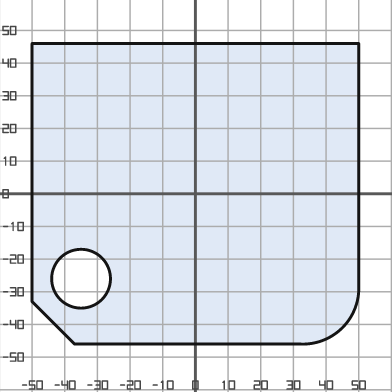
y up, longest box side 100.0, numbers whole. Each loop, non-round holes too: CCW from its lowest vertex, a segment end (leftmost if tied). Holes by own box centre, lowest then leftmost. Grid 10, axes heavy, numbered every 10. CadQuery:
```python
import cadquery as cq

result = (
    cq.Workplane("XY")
    .moveTo(-37.0, -46.0)
    .lineTo(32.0, -46.0)
    .threePointArc((45.0, -41.0), (50.0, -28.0))
    .lineTo(50.0, 46.0)
    .lineTo(-50.0, 46.0)
    .lineTo(-50.0, -33.0)
    .close()
    .moveTo(-35.0, -26.0)
    .circle(9.0)
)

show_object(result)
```